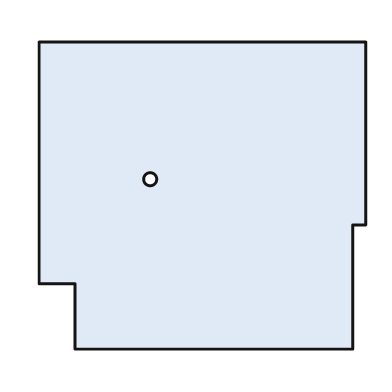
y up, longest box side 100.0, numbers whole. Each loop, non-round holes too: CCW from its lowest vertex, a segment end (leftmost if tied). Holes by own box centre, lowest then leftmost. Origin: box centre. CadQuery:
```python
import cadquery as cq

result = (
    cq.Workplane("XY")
    .moveTo(-39.0, -47.0)
    .lineTo(46.0, -47.0)
    .lineTo(46.0, -9.0)
    .lineTo(50.0, -9.0)
    .lineTo(50.0, 47.0)
    .lineTo(-50.0, 47.0)
    .lineTo(-50.0, -27.0)
    .lineTo(-39.0, -27.0)
    .close()
    .moveTo(-16.0, 5.0)
    .circle(2.0)
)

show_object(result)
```